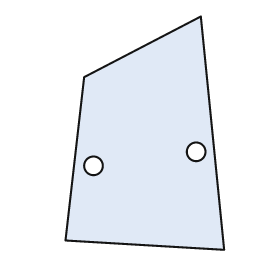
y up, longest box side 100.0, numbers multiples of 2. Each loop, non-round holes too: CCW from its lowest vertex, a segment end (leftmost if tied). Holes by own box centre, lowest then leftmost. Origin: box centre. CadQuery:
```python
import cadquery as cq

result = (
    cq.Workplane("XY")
    .moveTo(34.0, -50.0)
    .lineTo(24.0, 50.0)
    .lineTo(-26.0, 24.0)
    .lineTo(-34.0, -46.0)
    .close()
    .moveTo(-22.0, -14.0)
    .circle(4.0)
    .moveTo(22.0, -8.0)
    .circle(4.0)
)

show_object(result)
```